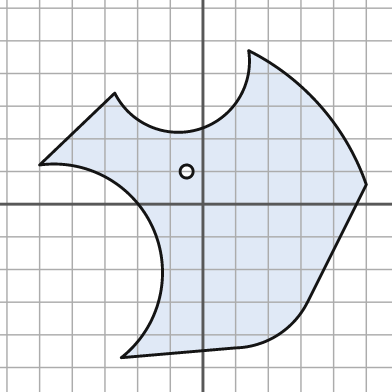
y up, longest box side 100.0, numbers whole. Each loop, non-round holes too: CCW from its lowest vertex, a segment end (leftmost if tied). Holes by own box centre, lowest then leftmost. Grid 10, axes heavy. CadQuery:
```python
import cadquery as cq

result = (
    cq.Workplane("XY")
    .moveTo(-25.0, -47.0)
    .lineTo(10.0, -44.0)
    .threePointArc((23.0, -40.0), (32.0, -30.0))
    .lineTo(50.0, 6.0)
    .threePointArc((36.0, 30.0), (14.0, 47.0))
    .threePointArc((-1.0, 23.0), (-27.0, 34.0))
    .lineTo(-50.0, 12.0)
    .threePointArc((-15.0, -8.0), (-25.0, -47.0))
    .close()
    .moveTo(-5.0, 10.0)
    .circle(2.0)
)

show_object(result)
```